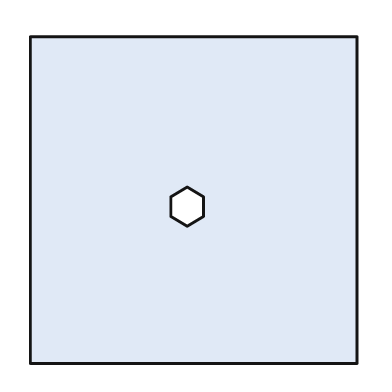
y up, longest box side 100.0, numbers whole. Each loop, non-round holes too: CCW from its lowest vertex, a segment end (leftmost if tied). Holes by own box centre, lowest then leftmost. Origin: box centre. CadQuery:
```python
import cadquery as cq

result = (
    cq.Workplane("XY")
    .moveTo(-50.0, -50.0)
    .lineTo(50.0, -50.0)
    .lineTo(50.0, 50.0)
    .lineTo(-50.0, 50.0)
    .close()
    .moveTo(-2.0, -8.0)
    .lineTo(3.0, -5.0)
    .lineTo(3.0, 1.0)
    .lineTo(-2.0, 4.0)
    .lineTo(-7.0, 1.0)
    .lineTo(-7.0, -5.0)
    .close()
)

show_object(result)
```